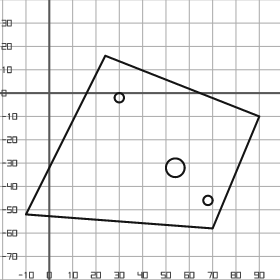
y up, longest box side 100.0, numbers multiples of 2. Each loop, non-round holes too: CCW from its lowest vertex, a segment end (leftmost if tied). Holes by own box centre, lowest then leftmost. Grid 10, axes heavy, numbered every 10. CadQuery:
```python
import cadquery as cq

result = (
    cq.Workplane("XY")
    .moveTo(70.0, -58.0)
    .lineTo(90.0, -10.0)
    .lineTo(24.0, 16.0)
    .lineTo(-10.0, -52.0)
    .close()
    .moveTo(68.0, -46.0)
    .circle(2.0)
    .moveTo(54.0, -32.0)
    .circle(4.0)
    .moveTo(30.0, -2.0)
    .circle(2.0)
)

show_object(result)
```